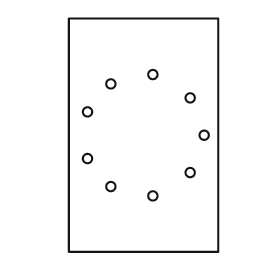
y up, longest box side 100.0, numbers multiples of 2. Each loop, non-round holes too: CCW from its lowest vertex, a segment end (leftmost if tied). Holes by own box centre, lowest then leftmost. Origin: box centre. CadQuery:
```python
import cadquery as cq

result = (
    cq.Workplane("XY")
    .moveTo(-32.0, -50.0)
    .lineTo(32.0, -50.0)
    .lineTo(32.0, 50.0)
    .lineTo(-32.0, 50.0)
    .close()
    .moveTo(4.0, -26.0)
    .circle(2.0)
    .moveTo(-14.0, -22.0)
    .circle(2.0)
    .moveTo(20.0, -16.0)
    .circle(2.0)
    .moveTo(-24.0, -10.0)
    .circle(2.0)
    .moveTo(26.0, 0.0)
    .circle(2.0)
    .moveTo(-24.0, 10.0)
    .circle(2.0)
    .moveTo(20.0, 16.0)
    .circle(2.0)
    .moveTo(-14.0, 22.0)
    .circle(2.0)
    .moveTo(4.0, 26.0)
    .circle(2.0)
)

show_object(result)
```